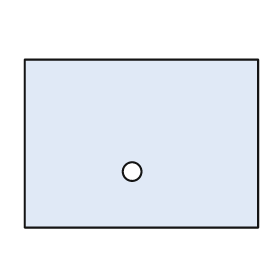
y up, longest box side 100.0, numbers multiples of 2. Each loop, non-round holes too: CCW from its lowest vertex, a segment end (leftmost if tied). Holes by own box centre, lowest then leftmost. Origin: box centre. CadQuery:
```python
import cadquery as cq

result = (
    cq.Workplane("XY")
    .moveTo(-50.0, -36.0)
    .lineTo(50.0, -36.0)
    .lineTo(50.0, 36.0)
    .lineTo(-50.0, 36.0)
    .close()
    .moveTo(-4.0, -12.0)
    .circle(4.0)
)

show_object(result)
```